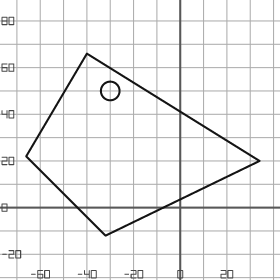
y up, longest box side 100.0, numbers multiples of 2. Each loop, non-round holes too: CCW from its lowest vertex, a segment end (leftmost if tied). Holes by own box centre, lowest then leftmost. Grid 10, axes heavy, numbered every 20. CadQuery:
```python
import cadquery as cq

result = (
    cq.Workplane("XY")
    .moveTo(-32.0, -12.0)
    .lineTo(34.0, 20.0)
    .lineTo(-40.0, 66.0)
    .lineTo(-66.0, 22.0)
    .close()
    .moveTo(-30.0, 50.0)
    .circle(4.0)
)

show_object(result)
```